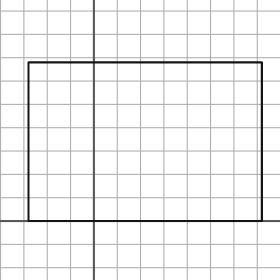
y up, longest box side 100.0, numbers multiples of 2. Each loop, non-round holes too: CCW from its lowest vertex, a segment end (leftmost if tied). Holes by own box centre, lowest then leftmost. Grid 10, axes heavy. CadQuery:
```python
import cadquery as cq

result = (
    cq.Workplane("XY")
    .moveTo(-28.0, 0.0)
    .lineTo(72.0, 0.0)
    .lineTo(72.0, 68.0)
    .lineTo(-28.0, 68.0)
    .close()
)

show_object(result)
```